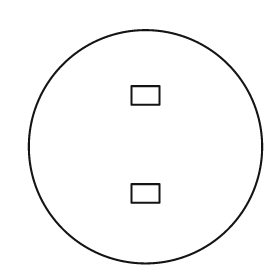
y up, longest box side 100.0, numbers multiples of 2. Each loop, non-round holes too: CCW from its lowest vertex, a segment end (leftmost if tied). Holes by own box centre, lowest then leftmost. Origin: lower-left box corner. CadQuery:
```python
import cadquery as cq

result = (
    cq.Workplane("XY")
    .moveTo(50.0, 50.0)
    .circle(50.0)
    .moveTo(44.0, 26.0)
    .lineTo(56.0, 26.0)
    .lineTo(56.0, 34.0)
    .lineTo(44.0, 34.0)
    .close()
    .moveTo(44.0, 68.0)
    .lineTo(56.0, 68.0)
    .lineTo(56.0, 76.0)
    .lineTo(44.0, 76.0)
    .close()
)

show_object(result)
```